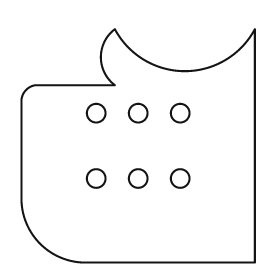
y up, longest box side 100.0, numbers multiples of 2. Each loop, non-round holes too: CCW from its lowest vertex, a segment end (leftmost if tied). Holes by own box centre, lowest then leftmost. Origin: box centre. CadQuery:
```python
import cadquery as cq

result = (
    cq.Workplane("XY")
    .moveTo(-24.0, -50.0)
    .lineTo(50.0, -50.0)
    .lineTo(50.0, 50.0)
    .threePointArc((20.0, 32.0), (-10.0, 50.0))
    .threePointArc((-16.0, 38.0), (-10.0, 26.0))
    .lineTo(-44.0, 26.0)
    .threePointArc((-48.0, 24.0), (-50.0, 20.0))
    .lineTo(-50.0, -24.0)
    .threePointArc((-42.0, -42.0), (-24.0, -50.0))
    .close()
    .moveTo(-18.0, -14.0)
    .circle(4.0)
    .moveTo(0.0, -14.0)
    .circle(4.0)
    .moveTo(18.0, -14.0)
    .circle(4.0)
    .moveTo(-18.0, 14.0)
    .circle(4.0)
    .moveTo(0.0, 14.0)
    .circle(4.0)
    .moveTo(18.0, 14.0)
    .circle(4.0)
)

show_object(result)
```